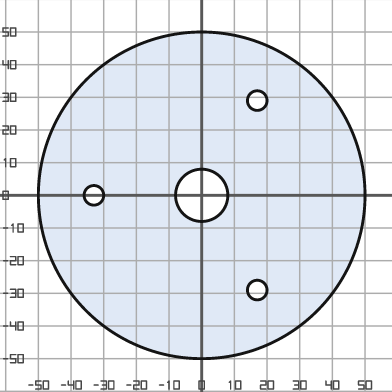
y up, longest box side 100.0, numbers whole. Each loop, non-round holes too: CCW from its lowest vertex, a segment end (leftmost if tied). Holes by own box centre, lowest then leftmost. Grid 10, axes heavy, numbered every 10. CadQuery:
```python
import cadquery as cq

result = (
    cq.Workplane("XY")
    .moveTo(0.0, 0.0)
    .circle(50.0)
    .moveTo(17.0, -29.0)
    .circle(3.0)
    .moveTo(-33.0, 0.0)
    .circle(3.0)
    .moveTo(0.0, 0.0)
    .circle(8.0)
    .moveTo(17.0, 29.0)
    .circle(3.0)
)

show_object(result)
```